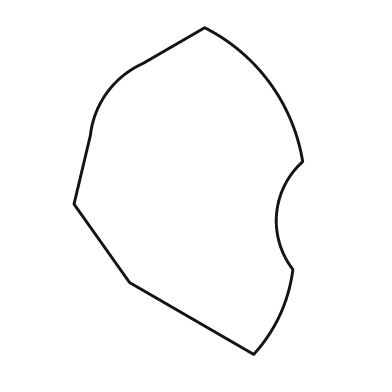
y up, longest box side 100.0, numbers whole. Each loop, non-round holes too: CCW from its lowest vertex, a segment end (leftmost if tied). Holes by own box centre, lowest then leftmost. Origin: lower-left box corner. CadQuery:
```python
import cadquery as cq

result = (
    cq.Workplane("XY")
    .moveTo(55.0, 0.0)
    .threePointArc((63.0, 12.0), (67.0, 26.0))
    .threePointArc((62.0, 43.0), (70.0, 59.0))
    .threePointArc((60.0, 83.0), (40.0, 100.0))
    .lineTo(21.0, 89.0)
    .threePointArc((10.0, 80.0), (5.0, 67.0))
    .lineTo(0.0, 46.0)
    .lineTo(17.0, 22.0)
    .close()
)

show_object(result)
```